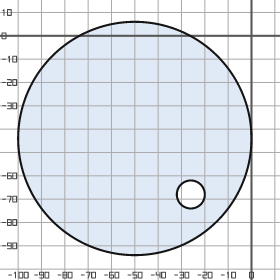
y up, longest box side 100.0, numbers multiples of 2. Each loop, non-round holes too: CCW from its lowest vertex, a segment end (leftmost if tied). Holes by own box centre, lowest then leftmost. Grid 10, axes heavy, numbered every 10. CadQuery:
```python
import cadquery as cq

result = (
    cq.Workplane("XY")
    .moveTo(-50.0, -44.0)
    .circle(50.0)
    .moveTo(-26.0, -68.0)
    .circle(6.0)
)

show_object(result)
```